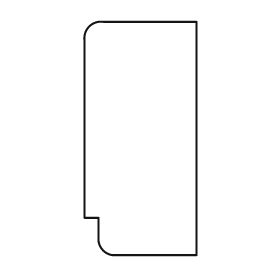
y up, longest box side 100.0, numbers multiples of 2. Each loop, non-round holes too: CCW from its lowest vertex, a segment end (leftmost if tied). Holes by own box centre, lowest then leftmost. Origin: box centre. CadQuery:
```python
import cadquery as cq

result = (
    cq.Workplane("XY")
    .moveTo(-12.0, -50.0)
    .lineTo(24.0, -50.0)
    .lineTo(24.0, 50.0)
    .lineTo(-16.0, 50.0)
    .threePointArc((-22.0, 48.0), (-24.0, 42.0))
    .lineTo(-24.0, -34.0)
    .lineTo(-18.0, -34.0)
    .lineTo(-18.0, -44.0)
    .threePointArc((-16.0, -48.0), (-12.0, -50.0))
    .close()
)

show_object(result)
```